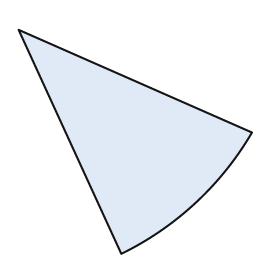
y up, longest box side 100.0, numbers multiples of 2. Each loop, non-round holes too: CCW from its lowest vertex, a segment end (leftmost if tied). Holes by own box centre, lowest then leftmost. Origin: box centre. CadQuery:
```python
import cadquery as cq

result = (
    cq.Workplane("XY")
    .moveTo(-6.0, -48.0)
    .threePointArc((26.0, -26.0), (50.0, 4.0))
    .lineTo(-50.0, 48.0)
    .close()
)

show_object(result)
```